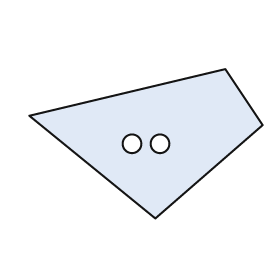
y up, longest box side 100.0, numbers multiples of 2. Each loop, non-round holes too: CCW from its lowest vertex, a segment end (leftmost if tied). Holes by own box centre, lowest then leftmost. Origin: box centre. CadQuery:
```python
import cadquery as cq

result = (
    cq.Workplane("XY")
    .moveTo(4.0, -32.0)
    .lineTo(50.0, 8.0)
    .lineTo(34.0, 32.0)
    .lineTo(-50.0, 12.0)
    .close()
    .moveTo(-6.0, 0.0)
    .circle(4.0)
    .moveTo(6.0, 0.0)
    .circle(4.0)
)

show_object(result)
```